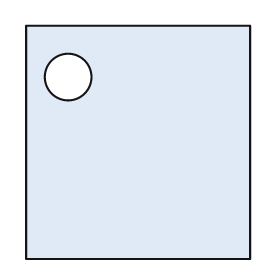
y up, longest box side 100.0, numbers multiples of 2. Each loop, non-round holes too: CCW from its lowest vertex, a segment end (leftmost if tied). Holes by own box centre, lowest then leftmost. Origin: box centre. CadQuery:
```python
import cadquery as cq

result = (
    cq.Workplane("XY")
    .moveTo(-48.0, -50.0)
    .lineTo(48.0, -50.0)
    .lineTo(48.0, 50.0)
    .lineTo(-48.0, 50.0)
    .close()
    .moveTo(-30.0, 28.0)
    .circle(10.0)
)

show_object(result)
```